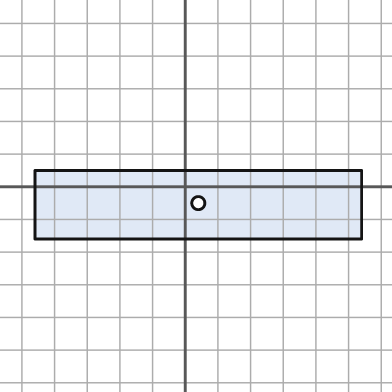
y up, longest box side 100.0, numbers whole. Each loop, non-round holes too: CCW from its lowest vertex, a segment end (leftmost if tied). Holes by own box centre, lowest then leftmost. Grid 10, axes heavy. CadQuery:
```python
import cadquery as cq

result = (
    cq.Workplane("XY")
    .moveTo(-46.0, -16.0)
    .lineTo(54.0, -16.0)
    .lineTo(54.0, 5.0)
    .lineTo(-46.0, 5.0)
    .close()
    .moveTo(4.0, -5.0)
    .circle(2.0)
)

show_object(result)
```